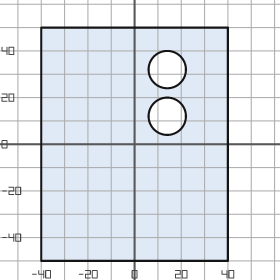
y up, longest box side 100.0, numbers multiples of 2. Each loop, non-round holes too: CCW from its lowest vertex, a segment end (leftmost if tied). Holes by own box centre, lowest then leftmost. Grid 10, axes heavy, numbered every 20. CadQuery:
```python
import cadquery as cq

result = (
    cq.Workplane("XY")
    .moveTo(-40.0, -50.0)
    .lineTo(40.0, -50.0)
    .lineTo(40.0, 50.0)
    .lineTo(-40.0, 50.0)
    .close()
    .moveTo(14.0, 12.0)
    .circle(8.0)
    .moveTo(14.0, 32.0)
    .circle(8.0)
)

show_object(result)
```